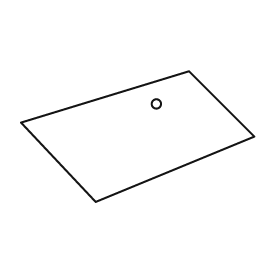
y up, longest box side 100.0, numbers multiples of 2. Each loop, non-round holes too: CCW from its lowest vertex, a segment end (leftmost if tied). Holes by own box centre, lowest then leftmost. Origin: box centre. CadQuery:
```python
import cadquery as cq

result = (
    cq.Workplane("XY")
    .moveTo(-18.0, -28.0)
    .lineTo(50.0, 0.0)
    .lineTo(22.0, 28.0)
    .lineTo(-50.0, 6.0)
    .close()
    .moveTo(8.0, 14.0)
    .circle(2.0)
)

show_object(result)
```